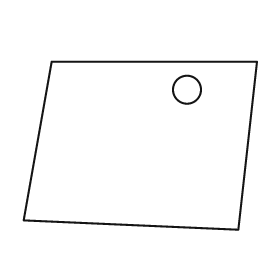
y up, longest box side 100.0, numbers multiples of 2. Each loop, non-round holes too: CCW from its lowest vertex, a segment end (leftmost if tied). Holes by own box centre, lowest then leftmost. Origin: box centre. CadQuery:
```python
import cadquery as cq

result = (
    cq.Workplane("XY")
    .moveTo(42.0, -36.0)
    .lineTo(50.0, 36.0)
    .lineTo(-38.0, 36.0)
    .lineTo(-50.0, -32.0)
    .close()
    .moveTo(20.0, 24.0)
    .circle(6.0)
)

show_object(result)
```